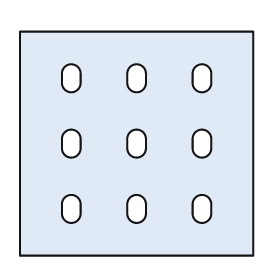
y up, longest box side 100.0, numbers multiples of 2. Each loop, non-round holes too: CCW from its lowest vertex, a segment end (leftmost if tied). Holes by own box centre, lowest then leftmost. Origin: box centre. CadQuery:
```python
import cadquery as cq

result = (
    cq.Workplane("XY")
    .moveTo(-50.0, -48.0)
    .lineTo(50.0, -48.0)
    .lineTo(50.0, 48.0)
    .lineTo(-50.0, 48.0)
    .close()
    .moveTo(-32.0, -30.0)
    .threePointArc((-28.0, -34.0), (-24.0, -30.0))
    .lineTo(-24.0, -26.0)
    .threePointArc((-28.0, -22.0), (-32.0, -26.0))
    .close()
    .moveTo(-4.0, -30.0)
    .threePointArc((0.0, -34.0), (4.0, -30.0))
    .lineTo(4.0, -26.0)
    .threePointArc((0.0, -22.0), (-4.0, -26.0))
    .close()
    .moveTo(24.0, -30.0)
    .threePointArc((28.0, -34.0), (32.0, -30.0))
    .lineTo(32.0, -26.0)
    .threePointArc((28.0, -22.0), (24.0, -26.0))
    .close()
    .moveTo(-32.0, -2.0)
    .threePointArc((-28.0, -6.0), (-24.0, -2.0))
    .lineTo(-24.0, 2.0)
    .threePointArc((-28.0, 6.0), (-32.0, 2.0))
    .close()
    .moveTo(-4.0, -2.0)
    .threePointArc((0.0, -6.0), (4.0, -2.0))
    .lineTo(4.0, 2.0)
    .threePointArc((0.0, 6.0), (-4.0, 2.0))
    .close()
    .moveTo(24.0, -2.0)
    .threePointArc((28.0, -6.0), (32.0, -2.0))
    .lineTo(32.0, 2.0)
    .threePointArc((28.0, 6.0), (24.0, 2.0))
    .close()
    .moveTo(-32.0, 26.0)
    .threePointArc((-28.0, 22.0), (-24.0, 26.0))
    .lineTo(-24.0, 30.0)
    .threePointArc((-28.0, 34.0), (-32.0, 30.0))
    .close()
    .moveTo(-4.0, 26.0)
    .threePointArc((0.0, 22.0), (4.0, 26.0))
    .lineTo(4.0, 30.0)
    .threePointArc((0.0, 34.0), (-4.0, 30.0))
    .close()
    .moveTo(24.0, 26.0)
    .threePointArc((28.0, 22.0), (32.0, 26.0))
    .lineTo(32.0, 30.0)
    .threePointArc((28.0, 34.0), (24.0, 30.0))
    .close()
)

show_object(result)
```